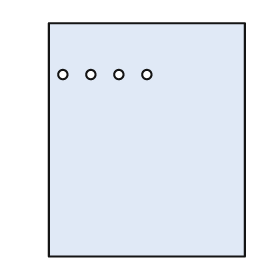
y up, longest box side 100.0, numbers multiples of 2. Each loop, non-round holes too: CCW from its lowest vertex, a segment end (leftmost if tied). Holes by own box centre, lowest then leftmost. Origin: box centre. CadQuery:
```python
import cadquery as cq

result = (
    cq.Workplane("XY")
    .moveTo(-42.0, -50.0)
    .lineTo(42.0, -50.0)
    .lineTo(42.0, 50.0)
    .lineTo(-42.0, 50.0)
    .close()
    .moveTo(-36.0, 28.0)
    .circle(2.0)
    .moveTo(-24.0, 28.0)
    .circle(2.0)
    .moveTo(-12.0, 28.0)
    .circle(2.0)
    .moveTo(0.0, 28.0)
    .circle(2.0)
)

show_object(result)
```